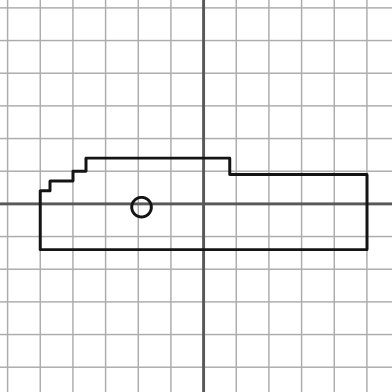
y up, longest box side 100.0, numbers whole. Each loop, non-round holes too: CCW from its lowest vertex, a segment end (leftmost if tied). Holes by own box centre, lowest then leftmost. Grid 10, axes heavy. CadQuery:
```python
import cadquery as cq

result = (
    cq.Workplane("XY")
    .moveTo(-50.0, -14.0)
    .lineTo(50.0, -14.0)
    .lineTo(50.0, 9.0)
    .lineTo(8.0, 9.0)
    .lineTo(8.0, 14.0)
    .lineTo(-36.0, 14.0)
    .lineTo(-36.0, 10.0)
    .lineTo(-40.0, 10.0)
    .lineTo(-40.0, 7.0)
    .lineTo(-47.0, 7.0)
    .lineTo(-47.0, 4.0)
    .lineTo(-50.0, 4.0)
    .close()
    .moveTo(-19.0, -1.0)
    .circle(3.0)
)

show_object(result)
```